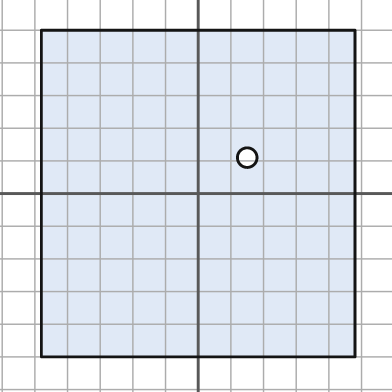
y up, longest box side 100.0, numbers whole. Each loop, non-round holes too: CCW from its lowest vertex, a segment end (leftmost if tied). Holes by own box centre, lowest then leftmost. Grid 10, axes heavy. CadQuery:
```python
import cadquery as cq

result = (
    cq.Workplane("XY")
    .moveTo(-48.0, -50.0)
    .lineTo(48.0, -50.0)
    .lineTo(48.0, 50.0)
    .lineTo(-48.0, 50.0)
    .close()
    .moveTo(15.0, 11.0)
    .circle(3.0)
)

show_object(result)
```